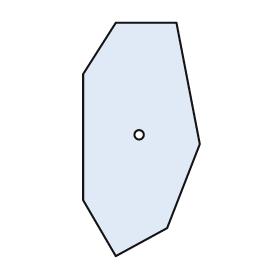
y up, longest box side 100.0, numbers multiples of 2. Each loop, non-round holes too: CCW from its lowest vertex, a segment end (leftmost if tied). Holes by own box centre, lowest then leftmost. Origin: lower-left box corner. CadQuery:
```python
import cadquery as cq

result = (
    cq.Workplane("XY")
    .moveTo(14.0, 0.0)
    .lineTo(36.0, 12.0)
    .lineTo(50.0, 48.0)
    .lineTo(40.0, 100.0)
    .lineTo(14.0, 100.0)
    .lineTo(0.0, 78.0)
    .lineTo(0.0, 24.0)
    .close()
    .moveTo(24.0, 52.0)
    .circle(2.0)
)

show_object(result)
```